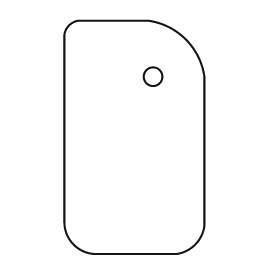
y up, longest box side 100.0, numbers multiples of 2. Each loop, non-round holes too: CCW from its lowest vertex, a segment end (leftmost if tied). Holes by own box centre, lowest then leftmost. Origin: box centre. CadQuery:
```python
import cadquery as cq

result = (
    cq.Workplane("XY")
    .moveTo(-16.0, -50.0)
    .lineTo(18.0, -50.0)
    .threePointArc((26.0, -46.0), (30.0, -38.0))
    .lineTo(30.0, 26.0)
    .threePointArc((22.0, 42.0), (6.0, 50.0))
    .lineTo(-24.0, 50.0)
    .threePointArc((-28.0, 48.0), (-30.0, 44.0))
    .lineTo(-30.0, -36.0)
    .threePointArc((-26.0, -46.0), (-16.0, -50.0))
    .close()
    .moveTo(8.0, 26.0)
    .circle(4.0)
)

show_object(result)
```